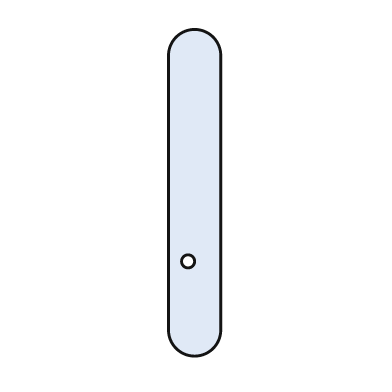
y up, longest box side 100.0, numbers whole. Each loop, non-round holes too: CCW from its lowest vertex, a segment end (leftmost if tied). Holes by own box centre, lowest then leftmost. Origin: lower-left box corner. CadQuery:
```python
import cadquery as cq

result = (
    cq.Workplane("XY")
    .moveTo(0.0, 8.0)
    .threePointArc((8.0, 0.0), (16.0, 8.0))
    .lineTo(16.0, 92.0)
    .threePointArc((8.0, 100.0), (0.0, 92.0))
    .close()
    .moveTo(6.0, 29.0)
    .circle(2.0)
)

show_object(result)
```